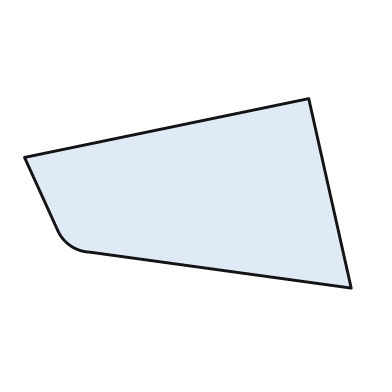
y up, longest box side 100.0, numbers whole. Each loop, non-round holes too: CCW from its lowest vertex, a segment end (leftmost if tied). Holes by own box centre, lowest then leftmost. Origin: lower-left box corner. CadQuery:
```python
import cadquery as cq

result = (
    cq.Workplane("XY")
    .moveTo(100.0, 0.0)
    .lineTo(87.0, 58.0)
    .lineTo(0.0, 40.0)
    .lineTo(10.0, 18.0)
    .threePointArc((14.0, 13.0), (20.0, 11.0))
    .close()
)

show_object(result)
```